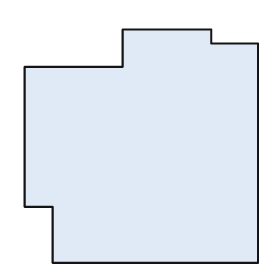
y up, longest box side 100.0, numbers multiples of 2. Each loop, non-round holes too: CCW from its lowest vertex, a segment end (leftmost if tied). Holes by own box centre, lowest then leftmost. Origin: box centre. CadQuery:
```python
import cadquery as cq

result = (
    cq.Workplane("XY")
    .moveTo(-38.0, -50.0)
    .lineTo(50.0, -50.0)
    .lineTo(50.0, 44.0)
    .lineTo(30.0, 44.0)
    .lineTo(30.0, 50.0)
    .lineTo(-8.0, 50.0)
    .lineTo(-8.0, 34.0)
    .lineTo(-50.0, 34.0)
    .lineTo(-50.0, -26.0)
    .lineTo(-38.0, -26.0)
    .close()
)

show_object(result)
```